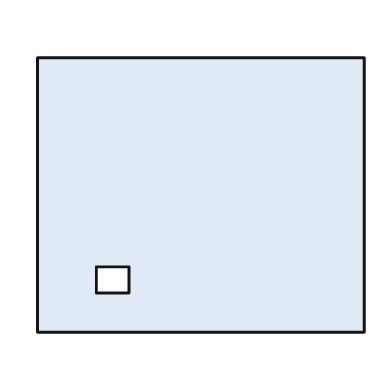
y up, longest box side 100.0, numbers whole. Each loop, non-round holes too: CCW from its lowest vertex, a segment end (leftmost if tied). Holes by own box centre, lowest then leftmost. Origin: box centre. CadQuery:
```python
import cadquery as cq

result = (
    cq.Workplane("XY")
    .moveTo(-50.0, -42.0)
    .lineTo(50.0, -42.0)
    .lineTo(50.0, 42.0)
    .lineTo(-50.0, 42.0)
    .close()
    .moveTo(-32.0, -30.0)
    .lineTo(-22.0, -30.0)
    .lineTo(-22.0, -22.0)
    .lineTo(-32.0, -22.0)
    .close()
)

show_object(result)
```